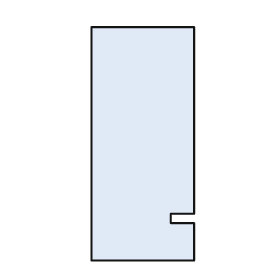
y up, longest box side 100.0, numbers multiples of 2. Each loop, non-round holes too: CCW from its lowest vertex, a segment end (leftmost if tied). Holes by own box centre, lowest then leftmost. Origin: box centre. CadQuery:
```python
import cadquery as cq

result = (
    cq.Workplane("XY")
    .moveTo(-22.0, -50.0)
    .lineTo(22.0, -50.0)
    .lineTo(22.0, -34.0)
    .lineTo(12.0, -34.0)
    .lineTo(12.0, -30.0)
    .lineTo(22.0, -30.0)
    .lineTo(22.0, 50.0)
    .lineTo(-22.0, 50.0)
    .close()
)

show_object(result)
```